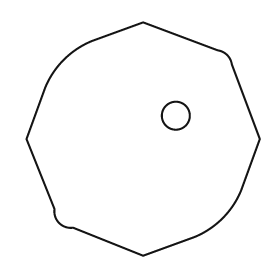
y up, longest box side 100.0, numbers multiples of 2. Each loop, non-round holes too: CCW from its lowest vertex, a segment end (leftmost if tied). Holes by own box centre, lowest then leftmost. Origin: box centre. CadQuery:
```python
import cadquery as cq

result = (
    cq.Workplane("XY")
    .moveTo(0.0, -50.0)
    .lineTo(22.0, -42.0)
    .threePointArc((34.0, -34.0), (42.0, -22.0))
    .lineTo(50.0, 0.0)
    .lineTo(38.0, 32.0)
    .threePointArc((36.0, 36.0), (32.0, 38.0))
    .lineTo(0.0, 50.0)
    .lineTo(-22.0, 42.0)
    .threePointArc((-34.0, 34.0), (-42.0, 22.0))
    .lineTo(-50.0, 0.0)
    .lineTo(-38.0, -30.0)
    .threePointArc((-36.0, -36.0), (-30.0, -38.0))
    .close()
    .moveTo(14.0, 10.0)
    .circle(6.0)
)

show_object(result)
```